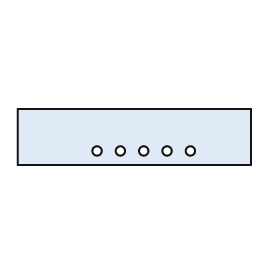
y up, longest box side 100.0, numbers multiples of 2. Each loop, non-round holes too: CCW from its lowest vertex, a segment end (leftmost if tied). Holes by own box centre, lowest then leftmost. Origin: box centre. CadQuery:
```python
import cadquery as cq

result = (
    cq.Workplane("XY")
    .moveTo(-50.0, -12.0)
    .lineTo(50.0, -12.0)
    .lineTo(50.0, 12.0)
    .lineTo(-50.0, 12.0)
    .close()
    .moveTo(-16.0, -6.0)
    .circle(2.0)
    .moveTo(-6.0, -6.0)
    .circle(2.0)
    .moveTo(4.0, -6.0)
    .circle(2.0)
    .moveTo(14.0, -6.0)
    .circle(2.0)
    .moveTo(24.0, -6.0)
    .circle(2.0)
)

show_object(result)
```